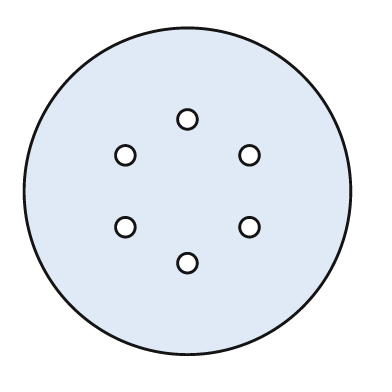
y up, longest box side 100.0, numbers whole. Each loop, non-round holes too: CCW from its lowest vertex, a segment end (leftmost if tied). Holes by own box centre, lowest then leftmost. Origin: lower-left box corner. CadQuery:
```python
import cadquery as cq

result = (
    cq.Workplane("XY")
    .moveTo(50.0, 50.0)
    .circle(50.0)
    .moveTo(50.0, 28.0)
    .circle(3.0)
    .moveTo(31.0, 39.0)
    .circle(3.0)
    .moveTo(69.0, 39.0)
    .circle(3.0)
    .moveTo(31.0, 61.0)
    .circle(3.0)
    .moveTo(69.0, 61.0)
    .circle(3.0)
    .moveTo(50.0, 72.0)
    .circle(3.0)
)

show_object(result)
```